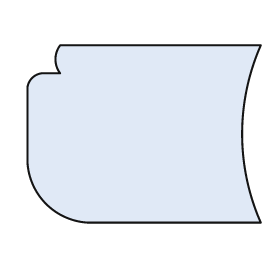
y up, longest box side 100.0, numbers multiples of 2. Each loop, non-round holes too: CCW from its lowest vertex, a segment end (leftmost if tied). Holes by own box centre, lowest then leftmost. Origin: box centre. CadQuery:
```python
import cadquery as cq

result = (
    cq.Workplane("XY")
    .moveTo(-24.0, -38.0)
    .lineTo(50.0, -38.0)
    .threePointArc((42.0, 0.0), (50.0, 38.0))
    .lineTo(-36.0, 38.0)
    .threePointArc((-38.0, 32.0), (-36.0, 26.0))
    .lineTo(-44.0, 26.0)
    .threePointArc((-48.0, 24.0), (-50.0, 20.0))
    .lineTo(-50.0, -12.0)
    .threePointArc((-42.0, -30.0), (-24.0, -38.0))
    .close()
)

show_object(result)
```